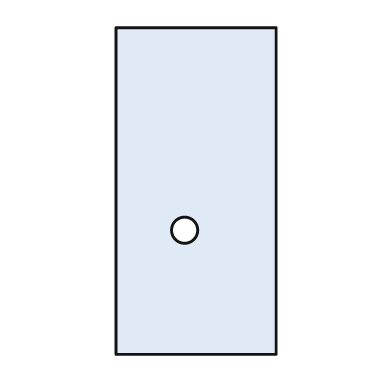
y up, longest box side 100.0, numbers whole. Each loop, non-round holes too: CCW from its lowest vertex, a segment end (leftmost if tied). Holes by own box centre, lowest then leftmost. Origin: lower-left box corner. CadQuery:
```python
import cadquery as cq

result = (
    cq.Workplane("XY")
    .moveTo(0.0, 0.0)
    .lineTo(49.0, 0.0)
    .lineTo(49.0, 100.0)
    .lineTo(0.0, 100.0)
    .close()
    .moveTo(21.0, 38.0)
    .circle(4.0)
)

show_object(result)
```